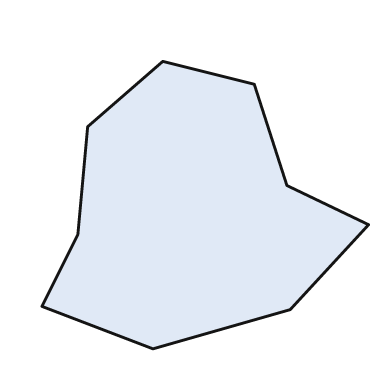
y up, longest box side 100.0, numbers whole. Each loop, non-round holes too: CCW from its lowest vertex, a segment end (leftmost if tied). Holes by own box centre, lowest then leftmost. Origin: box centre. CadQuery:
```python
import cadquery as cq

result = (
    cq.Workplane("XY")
    .moveTo(-16.0, -44.0)
    .lineTo(26.0, -32.0)
    .lineTo(50.0, -6.0)
    .lineTo(25.0, 6.0)
    .lineTo(15.0, 37.0)
    .lineTo(-13.0, 44.0)
    .lineTo(-36.0, 24.0)
    .lineTo(-39.0, -9.0)
    .lineTo(-50.0, -31.0)
    .close()
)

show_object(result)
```